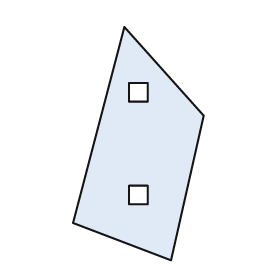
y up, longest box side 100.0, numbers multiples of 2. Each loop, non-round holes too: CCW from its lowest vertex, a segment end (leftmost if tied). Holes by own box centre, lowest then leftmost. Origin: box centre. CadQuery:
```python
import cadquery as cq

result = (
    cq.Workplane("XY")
    .moveTo(14.0, -50.0)
    .lineTo(28.0, 12.0)
    .lineTo(-6.0, 50.0)
    .lineTo(-28.0, -34.0)
    .close()
    .moveTo(-4.0, -26.0)
    .lineTo(4.0, -26.0)
    .lineTo(4.0, -18.0)
    .lineTo(-4.0, -18.0)
    .close()
    .moveTo(-4.0, 18.0)
    .lineTo(4.0, 18.0)
    .lineTo(4.0, 26.0)
    .lineTo(-4.0, 26.0)
    .close()
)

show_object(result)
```